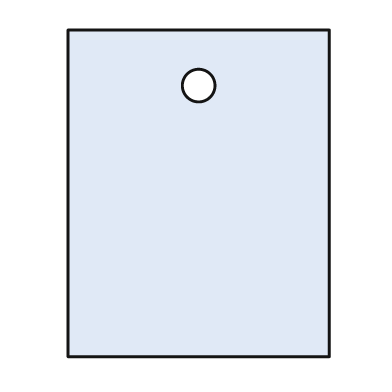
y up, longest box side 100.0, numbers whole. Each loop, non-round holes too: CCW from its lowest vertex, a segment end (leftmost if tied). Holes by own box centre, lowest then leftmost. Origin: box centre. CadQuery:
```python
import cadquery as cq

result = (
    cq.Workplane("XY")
    .moveTo(-40.0, -50.0)
    .lineTo(40.0, -50.0)
    .lineTo(40.0, 50.0)
    .lineTo(-40.0, 50.0)
    .close()
    .moveTo(0.0, 33.0)
    .circle(5.0)
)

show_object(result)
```